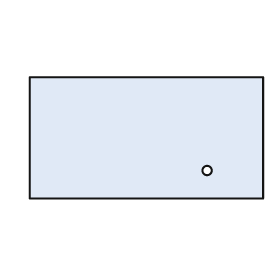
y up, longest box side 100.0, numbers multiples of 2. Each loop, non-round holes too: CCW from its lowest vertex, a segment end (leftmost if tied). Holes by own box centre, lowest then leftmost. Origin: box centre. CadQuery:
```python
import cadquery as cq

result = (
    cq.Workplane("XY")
    .moveTo(-50.0, -26.0)
    .lineTo(50.0, -26.0)
    .lineTo(50.0, 26.0)
    .lineTo(-50.0, 26.0)
    .close()
    .moveTo(26.0, -14.0)
    .circle(2.0)
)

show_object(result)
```